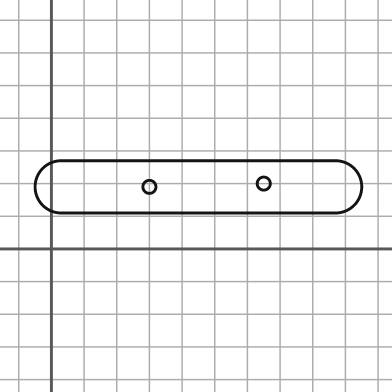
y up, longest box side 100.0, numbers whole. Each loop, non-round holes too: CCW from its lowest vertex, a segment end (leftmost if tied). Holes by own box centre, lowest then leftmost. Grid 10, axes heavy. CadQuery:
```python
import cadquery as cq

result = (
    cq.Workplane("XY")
    .moveTo(3.0, 11.0)
    .lineTo(87.0, 11.0)
    .threePointArc((95.0, 19.0), (87.0, 27.0))
    .lineTo(3.0, 27.0)
    .threePointArc((-5.0, 19.0), (3.0, 11.0))
    .close()
    .moveTo(30.0, 19.0)
    .circle(2.0)
    .moveTo(65.0, 20.0)
    .circle(2.0)
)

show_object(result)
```